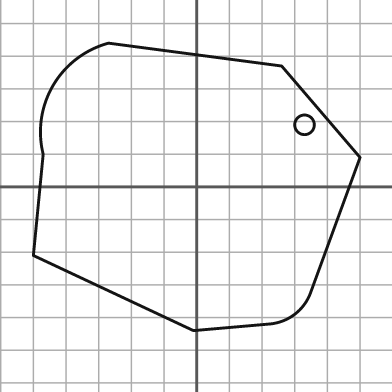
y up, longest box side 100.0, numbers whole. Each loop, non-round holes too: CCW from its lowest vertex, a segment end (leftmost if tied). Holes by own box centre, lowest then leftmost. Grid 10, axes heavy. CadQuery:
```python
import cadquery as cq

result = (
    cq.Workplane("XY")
    .moveTo(-1.0, -44.0)
    .lineTo(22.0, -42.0)
    .threePointArc((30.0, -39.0), (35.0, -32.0))
    .lineTo(50.0, 9.0)
    .lineTo(26.0, 37.0)
    .lineTo(-27.0, 44.0)
    .threePointArc((-44.0, 31.0), (-47.0, 10.0))
    .lineTo(-50.0, -21.0)
    .close()
    .moveTo(33.0, 19.0)
    .circle(3.0)
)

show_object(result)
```